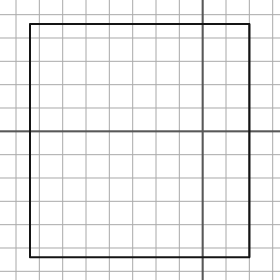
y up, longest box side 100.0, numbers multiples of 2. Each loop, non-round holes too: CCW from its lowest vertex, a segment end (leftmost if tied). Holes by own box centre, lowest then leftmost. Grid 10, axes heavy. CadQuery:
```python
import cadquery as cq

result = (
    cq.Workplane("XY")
    .moveTo(-74.0, -54.0)
    .lineTo(20.0, -54.0)
    .lineTo(20.0, 46.0)
    .lineTo(-74.0, 46.0)
    .close()
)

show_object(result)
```